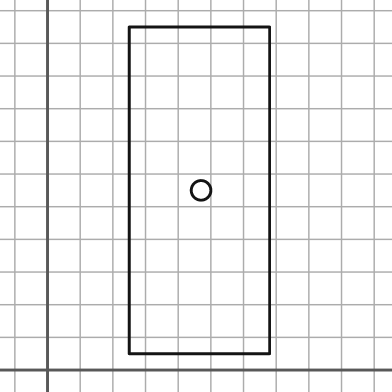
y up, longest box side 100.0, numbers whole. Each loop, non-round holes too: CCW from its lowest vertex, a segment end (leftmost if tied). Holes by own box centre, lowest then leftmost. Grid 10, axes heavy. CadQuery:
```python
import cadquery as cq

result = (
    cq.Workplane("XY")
    .moveTo(25.0, 5.0)
    .lineTo(68.0, 5.0)
    .lineTo(68.0, 105.0)
    .lineTo(25.0, 105.0)
    .close()
    .moveTo(47.0, 55.0)
    .circle(3.0)
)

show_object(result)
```